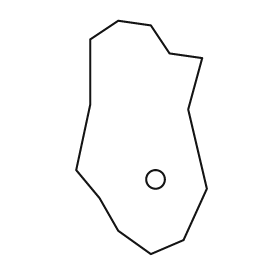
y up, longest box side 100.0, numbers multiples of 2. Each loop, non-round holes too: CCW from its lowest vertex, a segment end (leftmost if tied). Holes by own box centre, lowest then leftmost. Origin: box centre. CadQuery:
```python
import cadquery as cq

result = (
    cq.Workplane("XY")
    .moveTo(4.0, -50.0)
    .lineTo(18.0, -44.0)
    .lineTo(28.0, -22.0)
    .lineTo(20.0, 12.0)
    .lineTo(26.0, 34.0)
    .lineTo(12.0, 36.0)
    .lineTo(4.0, 48.0)
    .lineTo(-10.0, 50.0)
    .lineTo(-22.0, 42.0)
    .lineTo(-22.0, 14.0)
    .lineTo(-28.0, -14.0)
    .lineTo(-18.0, -26.0)
    .lineTo(-10.0, -40.0)
    .close()
    .moveTo(6.0, -18.0)
    .circle(4.0)
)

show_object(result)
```